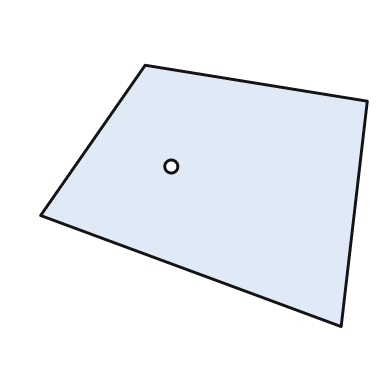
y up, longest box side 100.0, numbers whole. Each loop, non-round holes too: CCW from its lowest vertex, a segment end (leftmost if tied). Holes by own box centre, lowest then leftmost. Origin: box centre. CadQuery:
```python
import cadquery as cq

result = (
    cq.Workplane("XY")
    .moveTo(42.0, -40.0)
    .lineTo(50.0, 29.0)
    .lineTo(-18.0, 40.0)
    .lineTo(-50.0, -6.0)
    .close()
    .moveTo(-10.0, 9.0)
    .circle(2.0)
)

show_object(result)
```